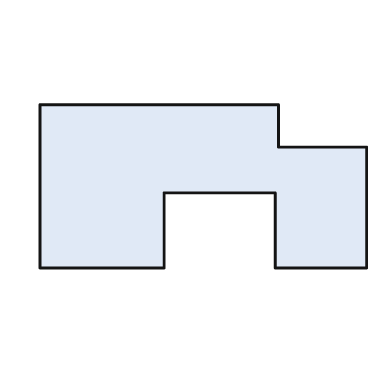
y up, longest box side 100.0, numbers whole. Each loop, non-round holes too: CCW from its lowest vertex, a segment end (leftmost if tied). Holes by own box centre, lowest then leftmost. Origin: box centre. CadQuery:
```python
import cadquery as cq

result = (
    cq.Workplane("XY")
    .moveTo(-50.0, -25.0)
    .lineTo(-12.0, -25.0)
    .lineTo(-12.0, -2.0)
    .lineTo(22.0, -2.0)
    .lineTo(22.0, -25.0)
    .lineTo(50.0, -25.0)
    .lineTo(50.0, 12.0)
    .lineTo(23.0, 12.0)
    .lineTo(23.0, 25.0)
    .lineTo(-50.0, 25.0)
    .close()
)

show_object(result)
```